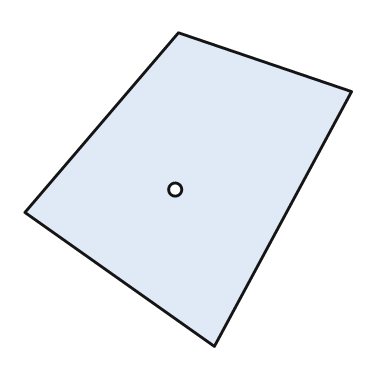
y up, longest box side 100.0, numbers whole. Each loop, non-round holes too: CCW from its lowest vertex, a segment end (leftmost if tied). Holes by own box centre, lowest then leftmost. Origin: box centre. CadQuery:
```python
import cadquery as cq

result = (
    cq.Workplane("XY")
    .moveTo(8.0, -48.0)
    .lineTo(50.0, 30.0)
    .lineTo(-3.0, 48.0)
    .lineTo(-50.0, -7.0)
    .close()
    .moveTo(-4.0, 0.0)
    .circle(2.0)
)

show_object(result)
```